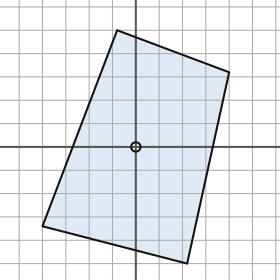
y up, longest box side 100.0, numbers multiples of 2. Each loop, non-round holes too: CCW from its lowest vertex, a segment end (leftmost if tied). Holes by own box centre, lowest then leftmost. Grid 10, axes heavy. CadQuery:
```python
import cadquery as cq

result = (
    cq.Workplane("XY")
    .moveTo(22.0, -50.0)
    .lineTo(40.0, 32.0)
    .lineTo(-8.0, 50.0)
    .lineTo(-40.0, -34.0)
    .close()
    .moveTo(0.0, 0.0)
    .circle(2.0)
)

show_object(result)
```